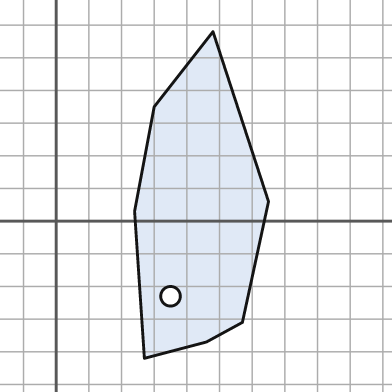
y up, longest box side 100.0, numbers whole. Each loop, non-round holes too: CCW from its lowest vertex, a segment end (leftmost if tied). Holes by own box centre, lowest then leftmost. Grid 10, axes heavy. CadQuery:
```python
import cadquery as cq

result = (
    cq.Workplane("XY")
    .moveTo(27.0, -42.0)
    .lineTo(46.0, -37.0)
    .lineTo(57.0, -31.0)
    .lineTo(65.0, 6.0)
    .lineTo(48.0, 58.0)
    .lineTo(30.0, 35.0)
    .lineTo(24.0, 3.0)
    .close()
    .moveTo(35.0, -23.0)
    .circle(3.0)
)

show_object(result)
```